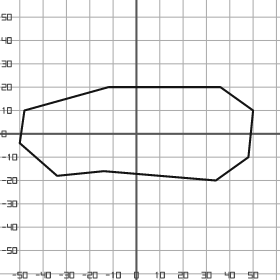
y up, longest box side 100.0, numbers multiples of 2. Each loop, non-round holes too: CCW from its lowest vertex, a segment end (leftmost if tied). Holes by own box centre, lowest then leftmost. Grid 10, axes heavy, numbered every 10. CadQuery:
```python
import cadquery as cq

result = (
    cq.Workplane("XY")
    .moveTo(34.0, -20.0)
    .lineTo(48.0, -10.0)
    .lineTo(50.0, 10.0)
    .lineTo(36.0, 20.0)
    .lineTo(-12.0, 20.0)
    .lineTo(-48.0, 10.0)
    .lineTo(-50.0, -4.0)
    .lineTo(-34.0, -18.0)
    .lineTo(-14.0, -16.0)
    .close()
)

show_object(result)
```